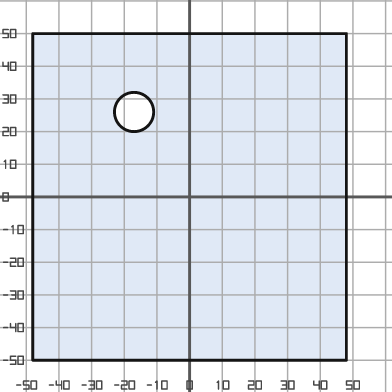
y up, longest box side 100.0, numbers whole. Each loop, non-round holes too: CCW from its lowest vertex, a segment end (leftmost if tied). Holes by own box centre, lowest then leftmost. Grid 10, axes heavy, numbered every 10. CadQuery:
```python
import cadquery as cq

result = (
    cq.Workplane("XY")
    .moveTo(-48.0, -50.0)
    .lineTo(48.0, -50.0)
    .lineTo(48.0, 50.0)
    .lineTo(-48.0, 50.0)
    .close()
    .moveTo(-17.0, 26.0)
    .circle(6.0)
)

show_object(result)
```